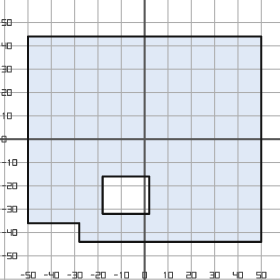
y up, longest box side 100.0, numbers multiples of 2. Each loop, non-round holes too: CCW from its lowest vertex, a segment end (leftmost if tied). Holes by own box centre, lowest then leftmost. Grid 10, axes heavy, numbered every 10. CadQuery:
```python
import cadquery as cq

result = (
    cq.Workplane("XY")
    .moveTo(-28.0, -44.0)
    .lineTo(50.0, -44.0)
    .lineTo(50.0, 44.0)
    .lineTo(-50.0, 44.0)
    .lineTo(-50.0, -36.0)
    .lineTo(-28.0, -36.0)
    .close()
    .moveTo(-18.0, -32.0)
    .lineTo(2.0, -32.0)
    .lineTo(2.0, -16.0)
    .lineTo(-18.0, -16.0)
    .close()
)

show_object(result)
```